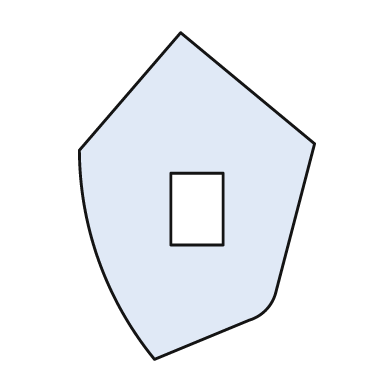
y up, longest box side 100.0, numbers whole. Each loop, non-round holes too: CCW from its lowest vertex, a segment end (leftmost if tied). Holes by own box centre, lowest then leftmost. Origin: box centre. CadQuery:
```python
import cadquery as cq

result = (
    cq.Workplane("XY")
    .moveTo(-13.0, -50.0)
    .lineTo(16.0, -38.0)
    .threePointArc((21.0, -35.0), (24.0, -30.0))
    .lineTo(36.0, 16.0)
    .lineTo(-5.0, 50.0)
    .lineTo(-36.0, 14.0)
    .threePointArc((-30.0, -20.0), (-13.0, -50.0))
    .close()
    .moveTo(-8.0, -15.0)
    .lineTo(8.0, -15.0)
    .lineTo(8.0, 7.0)
    .lineTo(-8.0, 7.0)
    .close()
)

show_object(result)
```